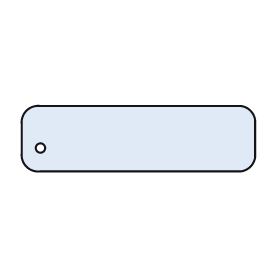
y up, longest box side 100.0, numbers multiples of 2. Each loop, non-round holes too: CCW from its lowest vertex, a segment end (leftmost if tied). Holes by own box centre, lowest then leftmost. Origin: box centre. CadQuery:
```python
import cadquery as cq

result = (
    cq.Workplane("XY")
    .moveTo(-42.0, -14.0)
    .lineTo(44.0, -14.0)
    .threePointArc((48.0, -12.0), (50.0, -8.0))
    .lineTo(50.0, 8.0)
    .threePointArc((48.0, 12.0), (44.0, 14.0))
    .lineTo(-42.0, 14.0)
    .threePointArc((-48.0, 12.0), (-50.0, 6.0))
    .lineTo(-50.0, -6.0)
    .threePointArc((-48.0, -12.0), (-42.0, -14.0))
    .close()
    .moveTo(-42.0, -4.0)
    .circle(2.0)
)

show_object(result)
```